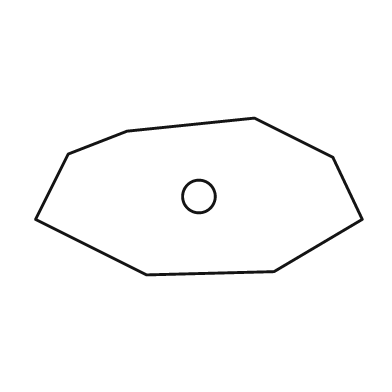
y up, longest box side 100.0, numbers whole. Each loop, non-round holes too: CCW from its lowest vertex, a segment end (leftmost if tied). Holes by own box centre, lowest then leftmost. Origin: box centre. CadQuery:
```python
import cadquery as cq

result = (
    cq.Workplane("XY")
    .moveTo(-16.0, -24.0)
    .lineTo(23.0, -23.0)
    .lineTo(50.0, -7.0)
    .lineTo(41.0, 12.0)
    .lineTo(17.0, 24.0)
    .lineTo(-22.0, 20.0)
    .lineTo(-40.0, 13.0)
    .lineTo(-50.0, -7.0)
    .close()
    .moveTo(0.0, 0.0)
    .circle(5.0)
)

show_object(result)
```